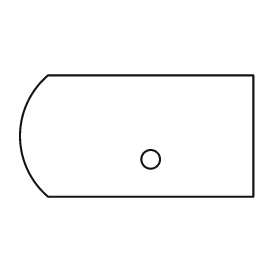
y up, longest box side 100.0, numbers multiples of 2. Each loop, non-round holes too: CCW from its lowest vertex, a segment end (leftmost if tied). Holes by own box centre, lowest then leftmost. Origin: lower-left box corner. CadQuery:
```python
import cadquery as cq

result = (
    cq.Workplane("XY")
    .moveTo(12.0, 0.0)
    .lineTo(100.0, 0.0)
    .lineTo(100.0, 52.0)
    .lineTo(12.0, 52.0)
    .threePointArc((0.0, 26.0), (12.0, 0.0))
    .close()
    .moveTo(56.0, 16.0)
    .circle(4.0)
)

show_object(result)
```